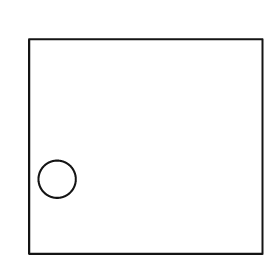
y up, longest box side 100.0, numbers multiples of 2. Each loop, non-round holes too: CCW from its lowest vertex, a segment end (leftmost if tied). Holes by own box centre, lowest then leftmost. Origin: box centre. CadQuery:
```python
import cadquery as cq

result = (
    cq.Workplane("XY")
    .moveTo(-50.0, -46.0)
    .lineTo(50.0, -46.0)
    .lineTo(50.0, 46.0)
    .lineTo(-50.0, 46.0)
    .close()
    .moveTo(-38.0, -14.0)
    .circle(8.0)
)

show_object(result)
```